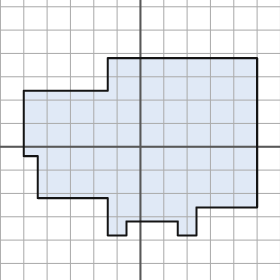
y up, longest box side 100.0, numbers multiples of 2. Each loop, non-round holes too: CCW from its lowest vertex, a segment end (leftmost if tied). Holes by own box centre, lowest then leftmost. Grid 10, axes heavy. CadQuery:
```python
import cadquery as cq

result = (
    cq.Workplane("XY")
    .moveTo(-14.0, -38.0)
    .lineTo(-6.0, -38.0)
    .lineTo(-6.0, -32.0)
    .lineTo(16.0, -32.0)
    .lineTo(16.0, -38.0)
    .lineTo(24.0, -38.0)
    .lineTo(24.0, -26.0)
    .lineTo(50.0, -26.0)
    .lineTo(50.0, 38.0)
    .lineTo(-14.0, 38.0)
    .lineTo(-14.0, 24.0)
    .lineTo(-50.0, 24.0)
    .lineTo(-50.0, -4.0)
    .lineTo(-44.0, -4.0)
    .lineTo(-44.0, -22.0)
    .lineTo(-14.0, -22.0)
    .close()
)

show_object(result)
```